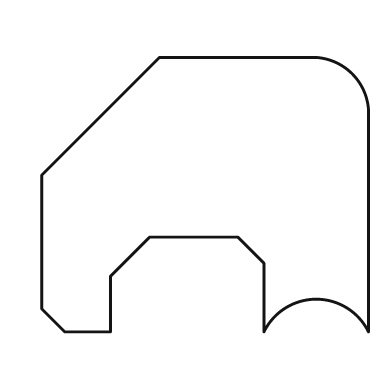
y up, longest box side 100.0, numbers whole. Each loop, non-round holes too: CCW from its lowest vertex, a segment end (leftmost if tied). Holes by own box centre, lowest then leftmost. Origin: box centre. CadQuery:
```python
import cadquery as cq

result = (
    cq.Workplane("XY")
    .moveTo(-43.0, -42.0)
    .lineTo(-29.0, -42.0)
    .lineTo(-29.0, -25.0)
    .lineTo(-17.0, -13.0)
    .lineTo(10.0, -13.0)
    .lineTo(18.0, -21.0)
    .lineTo(18.0, -42.0)
    .threePointArc((34.0, -32.0), (50.0, -42.0))
    .lineTo(50.0, 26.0)
    .threePointArc((45.0, 37.0), (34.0, 42.0))
    .lineTo(-14.0, 42.0)
    .lineTo(-50.0, 6.0)
    .lineTo(-50.0, -35.0)
    .close()
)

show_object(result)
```